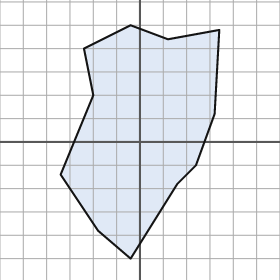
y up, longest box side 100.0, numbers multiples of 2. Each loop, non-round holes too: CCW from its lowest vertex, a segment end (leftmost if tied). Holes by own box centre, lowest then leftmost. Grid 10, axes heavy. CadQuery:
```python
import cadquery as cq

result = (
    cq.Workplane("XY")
    .moveTo(-4.0, -50.0)
    .lineTo(16.0, -18.0)
    .lineTo(24.0, -10.0)
    .lineTo(32.0, 12.0)
    .lineTo(34.0, 48.0)
    .lineTo(12.0, 44.0)
    .lineTo(-4.0, 50.0)
    .lineTo(-24.0, 40.0)
    .lineTo(-20.0, 20.0)
    .lineTo(-34.0, -14.0)
    .lineTo(-18.0, -38.0)
    .close()
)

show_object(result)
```